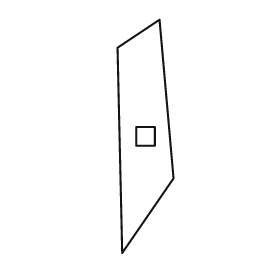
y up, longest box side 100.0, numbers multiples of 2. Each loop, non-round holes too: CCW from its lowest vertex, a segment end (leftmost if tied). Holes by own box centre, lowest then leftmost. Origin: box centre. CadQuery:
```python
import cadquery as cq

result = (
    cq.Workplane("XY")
    .moveTo(-10.0, -50.0)
    .lineTo(12.0, -18.0)
    .lineTo(6.0, 50.0)
    .lineTo(-12.0, 38.0)
    .close()
    .moveTo(-4.0, -4.0)
    .lineTo(4.0, -4.0)
    .lineTo(4.0, 4.0)
    .lineTo(-4.0, 4.0)
    .close()
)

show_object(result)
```